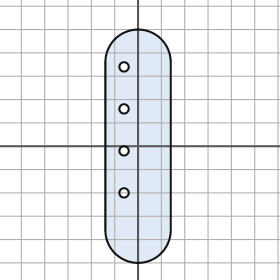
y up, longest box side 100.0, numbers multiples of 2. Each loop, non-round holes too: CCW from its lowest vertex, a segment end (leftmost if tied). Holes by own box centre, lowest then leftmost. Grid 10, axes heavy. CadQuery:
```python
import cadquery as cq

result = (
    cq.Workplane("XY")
    .moveTo(-14.0, -36.0)
    .threePointArc((0.0, -50.0), (14.0, -36.0))
    .lineTo(14.0, 36.0)
    .threePointArc((0.0, 50.0), (-14.0, 36.0))
    .close()
    .moveTo(-6.0, -20.0)
    .circle(2.0)
    .moveTo(-6.0, -2.0)
    .circle(2.0)
    .moveTo(-6.0, 16.0)
    .circle(2.0)
    .moveTo(-6.0, 34.0)
    .circle(2.0)
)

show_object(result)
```